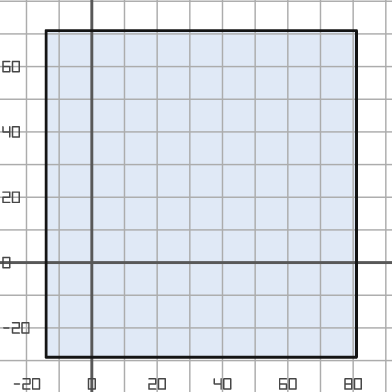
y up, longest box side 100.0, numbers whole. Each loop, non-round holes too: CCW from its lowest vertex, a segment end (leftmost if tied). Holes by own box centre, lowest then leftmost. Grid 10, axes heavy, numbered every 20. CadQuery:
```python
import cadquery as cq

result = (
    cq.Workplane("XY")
    .moveTo(-14.0, -29.0)
    .lineTo(81.0, -29.0)
    .lineTo(81.0, 71.0)
    .lineTo(-14.0, 71.0)
    .close()
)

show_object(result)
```